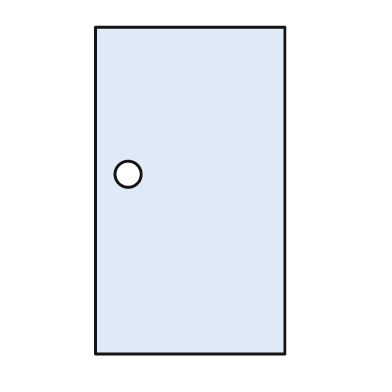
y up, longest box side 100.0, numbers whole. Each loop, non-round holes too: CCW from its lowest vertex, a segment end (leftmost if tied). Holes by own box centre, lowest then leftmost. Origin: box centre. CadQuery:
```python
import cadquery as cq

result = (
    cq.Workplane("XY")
    .moveTo(-29.0, -50.0)
    .lineTo(29.0, -50.0)
    .lineTo(29.0, 50.0)
    .lineTo(-29.0, 50.0)
    .close()
    .moveTo(-19.0, 5.0)
    .circle(4.0)
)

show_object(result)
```